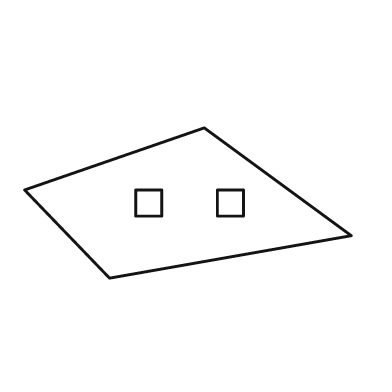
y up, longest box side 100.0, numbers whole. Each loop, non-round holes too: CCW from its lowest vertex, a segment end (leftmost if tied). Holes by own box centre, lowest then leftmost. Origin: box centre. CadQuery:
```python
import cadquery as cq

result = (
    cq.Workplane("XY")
    .moveTo(-24.0, -23.0)
    .lineTo(50.0, -10.0)
    .lineTo(5.0, 23.0)
    .lineTo(-50.0, 4.0)
    .close()
    .moveTo(-16.0, -4.0)
    .lineTo(-8.0, -4.0)
    .lineTo(-8.0, 4.0)
    .lineTo(-16.0, 4.0)
    .close()
    .moveTo(9.0, -4.0)
    .lineTo(17.0, -4.0)
    .lineTo(17.0, 4.0)
    .lineTo(9.0, 4.0)
    .close()
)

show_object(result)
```